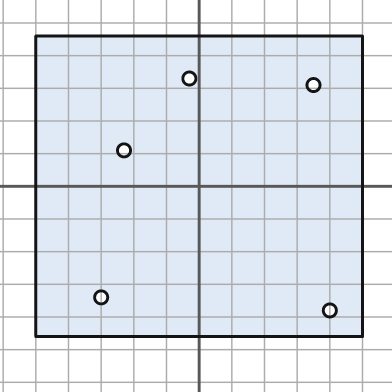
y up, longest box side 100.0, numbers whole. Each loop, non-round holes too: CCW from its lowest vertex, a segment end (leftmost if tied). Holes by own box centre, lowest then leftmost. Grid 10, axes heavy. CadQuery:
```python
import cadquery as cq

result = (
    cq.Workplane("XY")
    .moveTo(-50.0, -46.0)
    .lineTo(50.0, -46.0)
    .lineTo(50.0, 46.0)
    .lineTo(-50.0, 46.0)
    .close()
    .moveTo(40.0, -38.0)
    .circle(2.0)
    .moveTo(-30.0, -34.0)
    .circle(2.0)
    .moveTo(-23.0, 11.0)
    .circle(2.0)
    .moveTo(35.0, 31.0)
    .circle(2.0)
    .moveTo(-3.0, 33.0)
    .circle(2.0)
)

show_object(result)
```